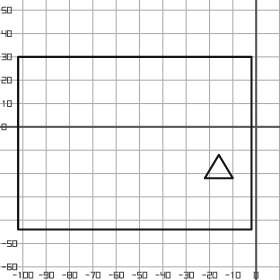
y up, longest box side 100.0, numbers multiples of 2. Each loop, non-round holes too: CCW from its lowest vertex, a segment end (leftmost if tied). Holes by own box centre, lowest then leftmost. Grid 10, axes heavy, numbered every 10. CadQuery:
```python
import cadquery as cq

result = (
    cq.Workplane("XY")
    .moveTo(-102.0, -44.0)
    .lineTo(-2.0, -44.0)
    .lineTo(-2.0, 30.0)
    .lineTo(-102.0, 30.0)
    .close()
    .moveTo(-22.0, -22.0)
    .lineTo(-10.0, -22.0)
    .lineTo(-16.0, -12.0)
    .close()
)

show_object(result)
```